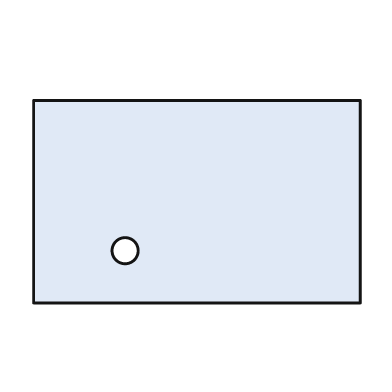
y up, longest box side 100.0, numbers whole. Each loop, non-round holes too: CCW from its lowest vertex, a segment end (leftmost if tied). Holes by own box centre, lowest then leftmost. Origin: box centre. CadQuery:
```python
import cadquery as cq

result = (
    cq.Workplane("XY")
    .moveTo(-50.0, -31.0)
    .lineTo(50.0, -31.0)
    .lineTo(50.0, 31.0)
    .lineTo(-50.0, 31.0)
    .close()
    .moveTo(-22.0, -15.0)
    .circle(4.0)
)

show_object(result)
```